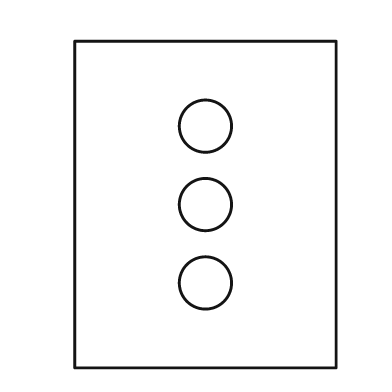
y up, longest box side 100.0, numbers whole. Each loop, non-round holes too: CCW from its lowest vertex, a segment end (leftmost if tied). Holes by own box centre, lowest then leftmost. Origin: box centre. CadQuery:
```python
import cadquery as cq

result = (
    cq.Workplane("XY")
    .moveTo(-40.0, -50.0)
    .lineTo(40.0, -50.0)
    .lineTo(40.0, 50.0)
    .lineTo(-40.0, 50.0)
    .close()
    .moveTo(0.0, -24.0)
    .circle(8.0)
    .moveTo(0.0, 0.0)
    .circle(8.0)
    .moveTo(0.0, 24.0)
    .circle(8.0)
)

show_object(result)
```